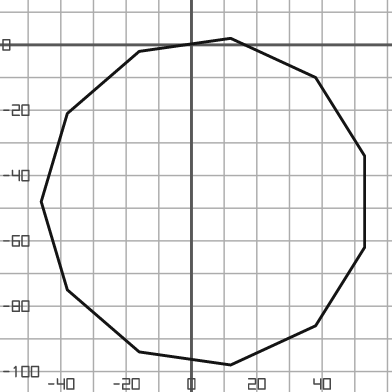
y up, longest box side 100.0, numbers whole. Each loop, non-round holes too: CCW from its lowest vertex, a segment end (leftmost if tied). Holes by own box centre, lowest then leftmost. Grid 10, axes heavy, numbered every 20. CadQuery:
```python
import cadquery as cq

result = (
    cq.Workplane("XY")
    .moveTo(12.0, -98.0)
    .lineTo(38.0, -86.0)
    .lineTo(53.0, -62.0)
    .lineTo(53.0, -34.0)
    .lineTo(38.0, -10.0)
    .lineTo(12.0, 2.0)
    .lineTo(-16.0, -2.0)
    .lineTo(-38.0, -21.0)
    .lineTo(-46.0, -48.0)
    .lineTo(-38.0, -75.0)
    .lineTo(-16.0, -94.0)
    .close()
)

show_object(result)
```